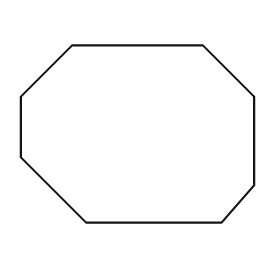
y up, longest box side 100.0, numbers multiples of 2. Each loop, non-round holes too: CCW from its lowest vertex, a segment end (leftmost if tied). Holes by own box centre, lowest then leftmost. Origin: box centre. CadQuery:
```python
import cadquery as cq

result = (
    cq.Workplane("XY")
    .moveTo(-22.0, -38.0)
    .lineTo(36.0, -38.0)
    .lineTo(50.0, -22.0)
    .lineTo(50.0, 16.0)
    .lineTo(28.0, 38.0)
    .lineTo(-28.0, 38.0)
    .lineTo(-50.0, 16.0)
    .lineTo(-50.0, -10.0)
    .close()
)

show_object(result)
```